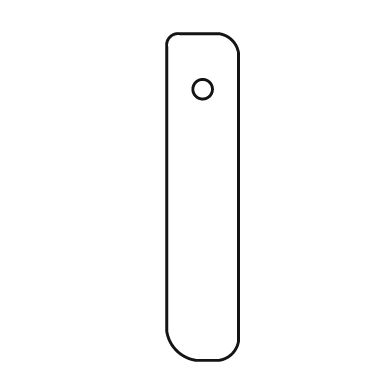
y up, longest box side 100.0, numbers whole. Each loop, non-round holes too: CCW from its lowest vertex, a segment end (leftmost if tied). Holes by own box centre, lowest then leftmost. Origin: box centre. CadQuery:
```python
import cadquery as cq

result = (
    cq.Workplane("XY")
    .moveTo(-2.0, -50.0)
    .lineTo(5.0, -50.0)
    .threePointArc((9.0, -48.0), (11.0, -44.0))
    .lineTo(11.0, 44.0)
    .threePointArc((9.0, 48.0), (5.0, 50.0))
    .lineTo(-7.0, 50.0)
    .threePointArc((-10.0, 49.0), (-11.0, 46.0))
    .lineTo(-11.0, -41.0)
    .threePointArc((-8.0, -47.0), (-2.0, -50.0))
    .close()
    .moveTo(0.0, 33.0)
    .circle(3.0)
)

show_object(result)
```